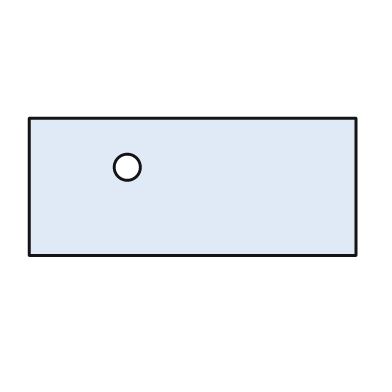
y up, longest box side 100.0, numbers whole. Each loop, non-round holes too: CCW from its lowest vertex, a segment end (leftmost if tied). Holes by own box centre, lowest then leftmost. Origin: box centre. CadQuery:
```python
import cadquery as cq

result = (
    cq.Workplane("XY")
    .moveTo(-50.0, -21.0)
    .lineTo(50.0, -21.0)
    .lineTo(50.0, 21.0)
    .lineTo(-50.0, 21.0)
    .close()
    .moveTo(-20.0, 6.0)
    .circle(4.0)
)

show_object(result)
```